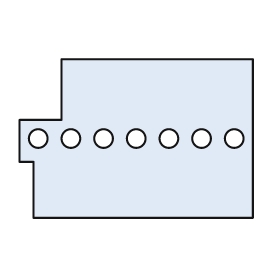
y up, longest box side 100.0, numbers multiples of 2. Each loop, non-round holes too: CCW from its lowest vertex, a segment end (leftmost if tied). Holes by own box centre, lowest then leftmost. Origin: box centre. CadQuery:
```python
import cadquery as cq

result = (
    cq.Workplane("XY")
    .moveTo(-44.0, -34.0)
    .lineTo(50.0, -34.0)
    .lineTo(50.0, 34.0)
    .lineTo(-32.0, 34.0)
    .lineTo(-32.0, 8.0)
    .lineTo(-50.0, 8.0)
    .lineTo(-50.0, -10.0)
    .lineTo(-44.0, -10.0)
    .close()
    .moveTo(-42.0, 0.0)
    .circle(4.0)
    .moveTo(-28.0, 0.0)
    .circle(4.0)
    .moveTo(-14.0, 0.0)
    .circle(4.0)
    .moveTo(0.0, 0.0)
    .circle(4.0)
    .moveTo(14.0, 0.0)
    .circle(4.0)
    .moveTo(28.0, 0.0)
    .circle(4.0)
    .moveTo(42.0, 0.0)
    .circle(4.0)
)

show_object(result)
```